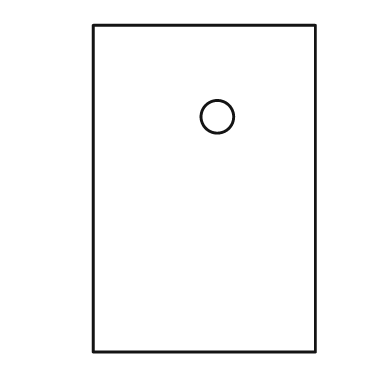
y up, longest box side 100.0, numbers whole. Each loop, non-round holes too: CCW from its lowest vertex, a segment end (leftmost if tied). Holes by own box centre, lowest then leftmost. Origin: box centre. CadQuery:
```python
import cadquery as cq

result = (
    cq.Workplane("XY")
    .moveTo(-34.0, -50.0)
    .lineTo(34.0, -50.0)
    .lineTo(34.0, 50.0)
    .lineTo(-34.0, 50.0)
    .close()
    .moveTo(4.0, 22.0)
    .circle(5.0)
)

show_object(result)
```